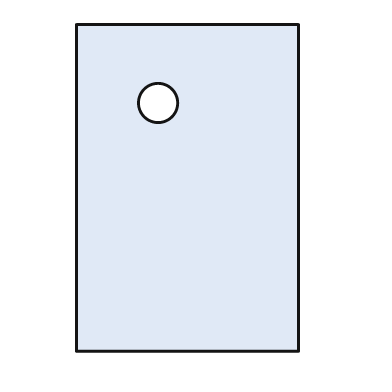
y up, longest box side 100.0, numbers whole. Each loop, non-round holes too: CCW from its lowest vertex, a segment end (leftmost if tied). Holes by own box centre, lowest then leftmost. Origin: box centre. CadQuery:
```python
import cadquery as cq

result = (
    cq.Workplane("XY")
    .moveTo(-34.0, -50.0)
    .lineTo(34.0, -50.0)
    .lineTo(34.0, 50.0)
    .lineTo(-34.0, 50.0)
    .close()
    .moveTo(-9.0, 26.0)
    .circle(6.0)
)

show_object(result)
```